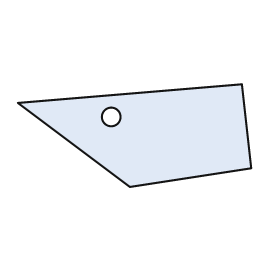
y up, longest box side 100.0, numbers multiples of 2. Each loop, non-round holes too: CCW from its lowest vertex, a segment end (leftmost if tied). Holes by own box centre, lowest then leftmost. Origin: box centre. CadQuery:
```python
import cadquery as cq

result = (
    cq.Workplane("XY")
    .moveTo(-2.0, -22.0)
    .lineTo(50.0, -14.0)
    .lineTo(46.0, 22.0)
    .lineTo(-50.0, 14.0)
    .close()
    .moveTo(-10.0, 8.0)
    .circle(4.0)
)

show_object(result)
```